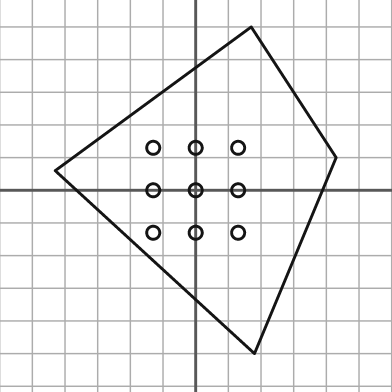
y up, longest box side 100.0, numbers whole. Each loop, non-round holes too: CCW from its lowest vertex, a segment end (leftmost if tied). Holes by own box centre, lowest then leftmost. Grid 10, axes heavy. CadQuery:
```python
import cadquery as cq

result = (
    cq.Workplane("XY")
    .moveTo(18.0, -50.0)
    .lineTo(43.0, 10.0)
    .lineTo(17.0, 50.0)
    .lineTo(-43.0, 6.0)
    .close()
    .moveTo(-13.0, -13.0)
    .circle(2.0)
    .moveTo(0.0, -13.0)
    .circle(2.0)
    .moveTo(13.0, -13.0)
    .circle(2.0)
    .moveTo(-13.0, 0.0)
    .circle(2.0)
    .moveTo(0.0, 0.0)
    .circle(2.0)
    .moveTo(13.0, 0.0)
    .circle(2.0)
    .moveTo(-13.0, 13.0)
    .circle(2.0)
    .moveTo(0.0, 13.0)
    .circle(2.0)
    .moveTo(13.0, 13.0)
    .circle(2.0)
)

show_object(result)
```